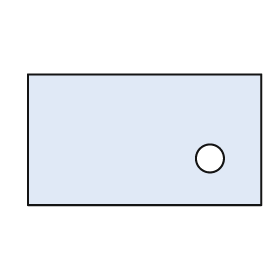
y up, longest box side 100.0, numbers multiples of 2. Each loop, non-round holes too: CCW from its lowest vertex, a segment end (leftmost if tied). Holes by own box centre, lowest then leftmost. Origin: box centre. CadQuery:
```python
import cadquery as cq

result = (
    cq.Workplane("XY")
    .moveTo(-50.0, -28.0)
    .lineTo(50.0, -28.0)
    .lineTo(50.0, 28.0)
    .lineTo(-50.0, 28.0)
    .close()
    .moveTo(28.0, -8.0)
    .circle(6.0)
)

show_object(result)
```